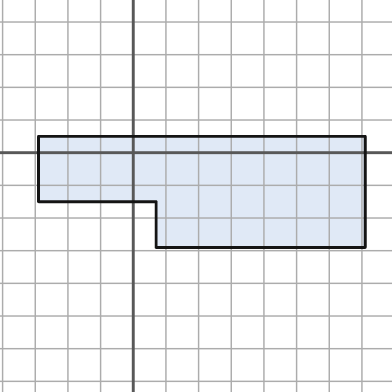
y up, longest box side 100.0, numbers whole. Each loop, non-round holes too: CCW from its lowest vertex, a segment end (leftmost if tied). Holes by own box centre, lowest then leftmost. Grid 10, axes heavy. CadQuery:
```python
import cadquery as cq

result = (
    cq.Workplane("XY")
    .moveTo(7.0, -29.0)
    .lineTo(71.0, -29.0)
    .lineTo(71.0, 5.0)
    .lineTo(-29.0, 5.0)
    .lineTo(-29.0, -15.0)
    .lineTo(7.0, -15.0)
    .close()
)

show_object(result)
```